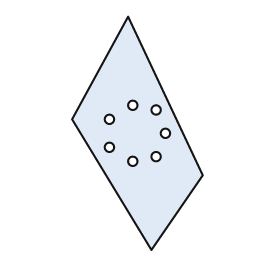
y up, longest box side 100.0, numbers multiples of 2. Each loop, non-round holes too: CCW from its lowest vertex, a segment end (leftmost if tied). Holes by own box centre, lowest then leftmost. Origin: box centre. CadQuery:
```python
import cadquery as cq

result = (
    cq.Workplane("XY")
    .moveTo(6.0, -50.0)
    .lineTo(28.0, -18.0)
    .lineTo(-4.0, 50.0)
    .lineTo(-28.0, 6.0)
    .close()
    .moveTo(-2.0, -12.0)
    .circle(2.0)
    .moveTo(8.0, -10.0)
    .circle(2.0)
    .moveTo(-12.0, -6.0)
    .circle(2.0)
    .moveTo(12.0, 0.0)
    .circle(2.0)
    .moveTo(-12.0, 6.0)
    .circle(2.0)
    .moveTo(8.0, 10.0)
    .circle(2.0)
    .moveTo(-2.0, 12.0)
    .circle(2.0)
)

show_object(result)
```